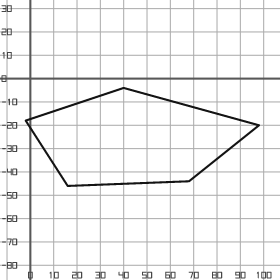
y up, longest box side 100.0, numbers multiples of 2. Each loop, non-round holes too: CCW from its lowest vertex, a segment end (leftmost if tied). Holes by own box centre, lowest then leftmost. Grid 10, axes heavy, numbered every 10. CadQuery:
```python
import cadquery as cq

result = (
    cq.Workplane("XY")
    .moveTo(16.0, -46.0)
    .lineTo(68.0, -44.0)
    .lineTo(98.0, -20.0)
    .lineTo(40.0, -4.0)
    .lineTo(-2.0, -18.0)
    .close()
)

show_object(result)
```